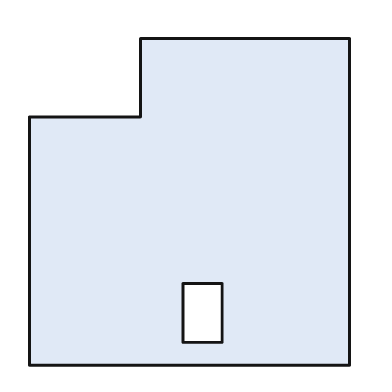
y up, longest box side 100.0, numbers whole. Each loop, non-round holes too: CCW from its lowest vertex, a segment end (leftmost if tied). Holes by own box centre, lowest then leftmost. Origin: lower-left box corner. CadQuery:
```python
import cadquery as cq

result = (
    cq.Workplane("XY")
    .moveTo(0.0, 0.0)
    .lineTo(98.0, 0.0)
    .lineTo(98.0, 100.0)
    .lineTo(34.0, 100.0)
    .lineTo(34.0, 76.0)
    .lineTo(0.0, 76.0)
    .close()
    .moveTo(47.0, 7.0)
    .lineTo(59.0, 7.0)
    .lineTo(59.0, 25.0)
    .lineTo(47.0, 25.0)
    .close()
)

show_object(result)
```